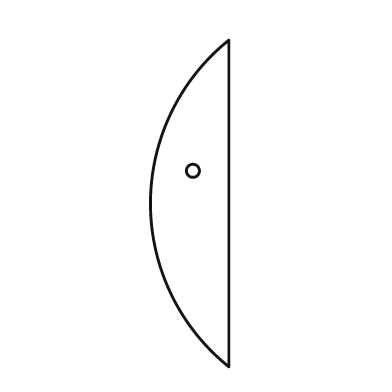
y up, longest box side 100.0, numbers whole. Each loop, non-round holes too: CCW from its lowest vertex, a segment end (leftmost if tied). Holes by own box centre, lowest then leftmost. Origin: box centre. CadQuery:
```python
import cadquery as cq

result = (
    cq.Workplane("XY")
    .moveTo(12.0, -50.0)
    .lineTo(12.0, 50.0)
    .threePointArc((-12.0, 0.0), (12.0, -50.0))
    .close()
    .moveTo(1.0, 10.0)
    .circle(2.0)
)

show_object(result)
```